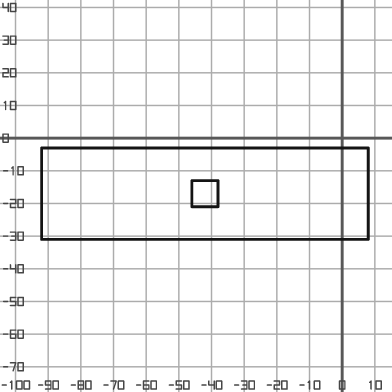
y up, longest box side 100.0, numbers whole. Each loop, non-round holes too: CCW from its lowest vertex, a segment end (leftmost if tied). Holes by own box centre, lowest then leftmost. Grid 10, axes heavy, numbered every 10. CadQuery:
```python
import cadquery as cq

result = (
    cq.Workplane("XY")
    .moveTo(-92.0, -31.0)
    .lineTo(8.0, -31.0)
    .lineTo(8.0, -3.0)
    .lineTo(-92.0, -3.0)
    .close()
    .moveTo(-46.0, -21.0)
    .lineTo(-38.0, -21.0)
    .lineTo(-38.0, -13.0)
    .lineTo(-46.0, -13.0)
    .close()
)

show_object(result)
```